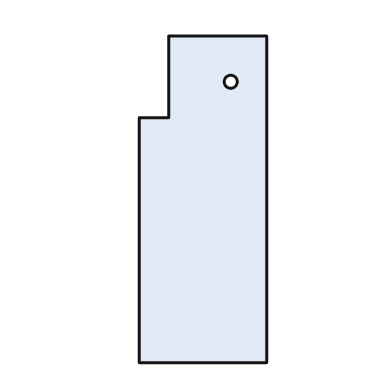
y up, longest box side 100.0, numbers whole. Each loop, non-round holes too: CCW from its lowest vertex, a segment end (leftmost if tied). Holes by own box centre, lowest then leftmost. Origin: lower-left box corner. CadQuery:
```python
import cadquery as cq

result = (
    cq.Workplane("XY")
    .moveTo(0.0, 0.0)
    .lineTo(39.0, 0.0)
    .lineTo(39.0, 100.0)
    .lineTo(9.0, 100.0)
    .lineTo(9.0, 75.0)
    .lineTo(0.0, 75.0)
    .close()
    .moveTo(28.0, 86.0)
    .circle(2.0)
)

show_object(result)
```